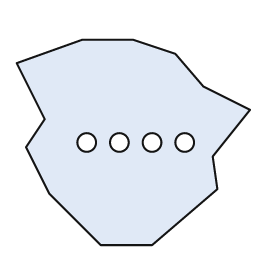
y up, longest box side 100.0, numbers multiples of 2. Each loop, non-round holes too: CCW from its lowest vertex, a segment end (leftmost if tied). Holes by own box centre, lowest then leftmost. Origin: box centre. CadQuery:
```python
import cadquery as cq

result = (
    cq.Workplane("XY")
    .moveTo(-14.0, -44.0)
    .lineTo(8.0, -44.0)
    .lineTo(36.0, -20.0)
    .lineTo(34.0, -6.0)
    .lineTo(50.0, 14.0)
    .lineTo(30.0, 24.0)
    .lineTo(18.0, 38.0)
    .lineTo(0.0, 44.0)
    .lineTo(-22.0, 44.0)
    .lineTo(-50.0, 34.0)
    .lineTo(-38.0, 10.0)
    .lineTo(-46.0, -2.0)
    .lineTo(-36.0, -22.0)
    .close()
    .moveTo(-20.0, 0.0)
    .circle(4.0)
    .moveTo(-6.0, 0.0)
    .circle(4.0)
    .moveTo(8.0, 0.0)
    .circle(4.0)
    .moveTo(22.0, 0.0)
    .circle(4.0)
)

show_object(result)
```